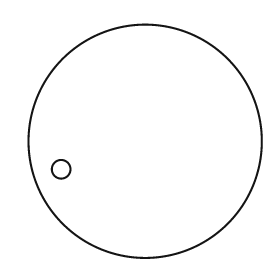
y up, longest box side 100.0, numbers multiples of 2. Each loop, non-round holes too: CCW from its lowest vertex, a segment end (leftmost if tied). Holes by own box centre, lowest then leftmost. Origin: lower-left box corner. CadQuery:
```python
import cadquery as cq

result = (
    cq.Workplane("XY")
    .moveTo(50.0, 50.0)
    .circle(50.0)
    .moveTo(14.0, 38.0)
    .circle(4.0)
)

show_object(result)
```